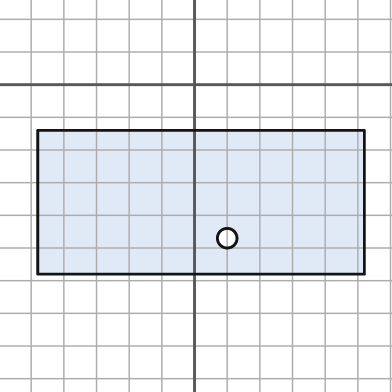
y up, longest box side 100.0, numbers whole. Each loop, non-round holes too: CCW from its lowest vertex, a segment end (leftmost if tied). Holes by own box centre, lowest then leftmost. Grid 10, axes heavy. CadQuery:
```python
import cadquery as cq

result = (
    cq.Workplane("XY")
    .moveTo(-48.0, -58.0)
    .lineTo(52.0, -58.0)
    .lineTo(52.0, -14.0)
    .lineTo(-48.0, -14.0)
    .close()
    .moveTo(10.0, -47.0)
    .circle(3.0)
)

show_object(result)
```